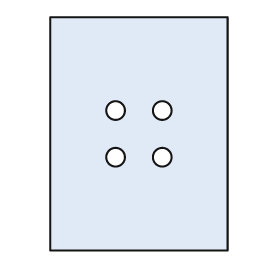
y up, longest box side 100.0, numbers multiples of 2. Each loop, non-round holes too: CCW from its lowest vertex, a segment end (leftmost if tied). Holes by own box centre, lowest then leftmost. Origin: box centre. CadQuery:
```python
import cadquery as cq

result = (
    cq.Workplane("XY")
    .moveTo(-38.0, -50.0)
    .lineTo(38.0, -50.0)
    .lineTo(38.0, 50.0)
    .lineTo(-38.0, 50.0)
    .close()
    .moveTo(-10.0, -10.0)
    .circle(4.0)
    .moveTo(10.0, -10.0)
    .circle(4.0)
    .moveTo(-10.0, 10.0)
    .circle(4.0)
    .moveTo(10.0, 10.0)
    .circle(4.0)
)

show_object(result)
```